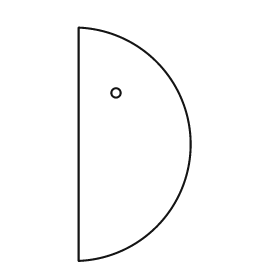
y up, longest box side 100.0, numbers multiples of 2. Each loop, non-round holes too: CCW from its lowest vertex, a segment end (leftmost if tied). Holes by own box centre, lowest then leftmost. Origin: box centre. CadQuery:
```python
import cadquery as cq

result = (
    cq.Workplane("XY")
    .moveTo(-24.0, -50.0)
    .threePointArc((24.0, 0.0), (-24.0, 50.0))
    .close()
    .moveTo(-8.0, 22.0)
    .circle(2.0)
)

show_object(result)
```